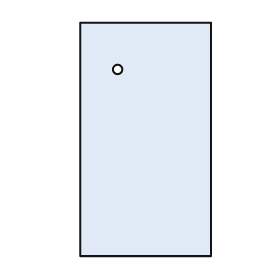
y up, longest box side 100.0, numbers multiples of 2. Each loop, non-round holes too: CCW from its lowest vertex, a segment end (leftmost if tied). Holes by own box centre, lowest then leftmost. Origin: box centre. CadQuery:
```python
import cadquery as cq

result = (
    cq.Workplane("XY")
    .moveTo(-28.0, -50.0)
    .lineTo(28.0, -50.0)
    .lineTo(28.0, 50.0)
    .lineTo(-28.0, 50.0)
    .close()
    .moveTo(-12.0, 30.0)
    .circle(2.0)
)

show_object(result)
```